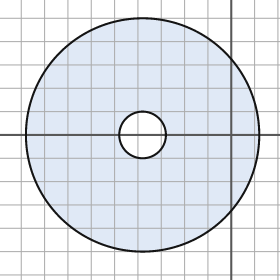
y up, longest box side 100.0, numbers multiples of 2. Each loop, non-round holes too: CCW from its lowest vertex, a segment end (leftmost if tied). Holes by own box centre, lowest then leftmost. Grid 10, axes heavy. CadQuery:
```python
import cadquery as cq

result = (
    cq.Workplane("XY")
    .moveTo(-38.0, 0.0)
    .circle(50.0)
    .moveTo(-38.0, 0.0)
    .circle(10.0)
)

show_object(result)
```